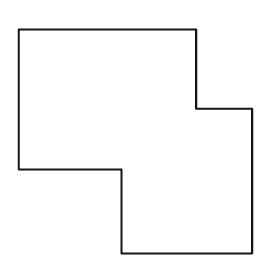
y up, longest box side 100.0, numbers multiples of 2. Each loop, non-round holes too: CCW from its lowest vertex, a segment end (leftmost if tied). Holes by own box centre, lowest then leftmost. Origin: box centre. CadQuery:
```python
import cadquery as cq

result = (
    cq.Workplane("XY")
    .moveTo(-6.0, -48.0)
    .lineTo(50.0, -48.0)
    .lineTo(50.0, 14.0)
    .lineTo(26.0, 14.0)
    .lineTo(26.0, 48.0)
    .lineTo(-50.0, 48.0)
    .lineTo(-50.0, -12.0)
    .lineTo(-6.0, -12.0)
    .close()
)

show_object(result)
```